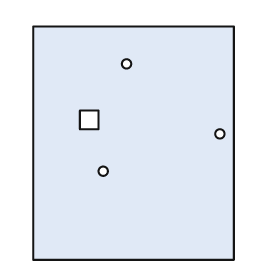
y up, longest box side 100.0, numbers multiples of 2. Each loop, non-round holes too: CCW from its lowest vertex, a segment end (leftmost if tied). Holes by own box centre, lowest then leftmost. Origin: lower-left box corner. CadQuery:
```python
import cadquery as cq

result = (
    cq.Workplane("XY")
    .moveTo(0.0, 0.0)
    .lineTo(86.0, 0.0)
    .lineTo(86.0, 100.0)
    .lineTo(0.0, 100.0)
    .close()
    .moveTo(30.0, 38.0)
    .circle(2.0)
    .moveTo(80.0, 54.0)
    .circle(2.0)
    .moveTo(20.0, 56.0)
    .lineTo(28.0, 56.0)
    .lineTo(28.0, 64.0)
    .lineTo(20.0, 64.0)
    .close()
    .moveTo(40.0, 84.0)
    .circle(2.0)
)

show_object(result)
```